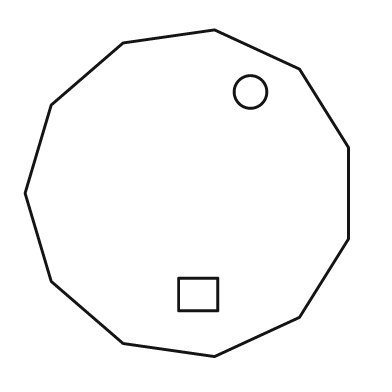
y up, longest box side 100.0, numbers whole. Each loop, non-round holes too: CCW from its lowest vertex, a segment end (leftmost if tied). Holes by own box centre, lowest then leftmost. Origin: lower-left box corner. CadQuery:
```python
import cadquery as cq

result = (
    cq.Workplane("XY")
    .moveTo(58.0, 0.0)
    .lineTo(84.0, 12.0)
    .lineTo(99.0, 36.0)
    .lineTo(99.0, 64.0)
    .lineTo(84.0, 88.0)
    .lineTo(58.0, 100.0)
    .lineTo(30.0, 96.0)
    .lineTo(8.0, 77.0)
    .lineTo(0.0, 50.0)
    .lineTo(8.0, 23.0)
    .lineTo(30.0, 4.0)
    .close()
    .moveTo(47.0, 14.0)
    .lineTo(59.0, 14.0)
    .lineTo(59.0, 24.0)
    .lineTo(47.0, 24.0)
    .close()
    .moveTo(69.0, 81.0)
    .circle(5.0)
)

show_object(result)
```